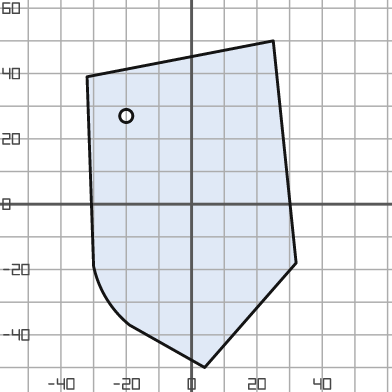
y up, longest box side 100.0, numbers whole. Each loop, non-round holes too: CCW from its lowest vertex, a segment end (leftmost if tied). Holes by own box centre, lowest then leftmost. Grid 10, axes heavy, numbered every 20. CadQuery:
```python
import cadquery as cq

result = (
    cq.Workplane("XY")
    .moveTo(4.0, -50.0)
    .lineTo(32.0, -18.0)
    .lineTo(25.0, 50.0)
    .lineTo(-32.0, 39.0)
    .lineTo(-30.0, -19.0)
    .threePointArc((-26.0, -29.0), (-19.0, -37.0))
    .close()
    .moveTo(-20.0, 27.0)
    .circle(2.0)
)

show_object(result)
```